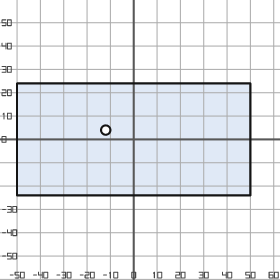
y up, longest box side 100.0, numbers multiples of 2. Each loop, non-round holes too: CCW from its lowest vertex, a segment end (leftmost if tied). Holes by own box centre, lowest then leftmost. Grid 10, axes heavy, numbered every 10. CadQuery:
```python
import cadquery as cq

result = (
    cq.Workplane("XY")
    .moveTo(-50.0, -24.0)
    .lineTo(50.0, -24.0)
    .lineTo(50.0, 24.0)
    .lineTo(-50.0, 24.0)
    .close()
    .moveTo(-12.0, 4.0)
    .circle(2.0)
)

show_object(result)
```